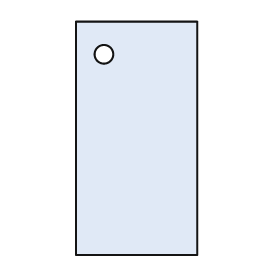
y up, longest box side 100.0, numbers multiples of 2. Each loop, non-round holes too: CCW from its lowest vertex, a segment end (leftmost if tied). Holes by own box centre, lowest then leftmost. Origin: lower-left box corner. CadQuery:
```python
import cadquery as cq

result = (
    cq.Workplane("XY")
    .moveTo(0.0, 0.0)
    .lineTo(52.0, 0.0)
    .lineTo(52.0, 100.0)
    .lineTo(0.0, 100.0)
    .close()
    .moveTo(12.0, 86.0)
    .circle(4.0)
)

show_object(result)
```